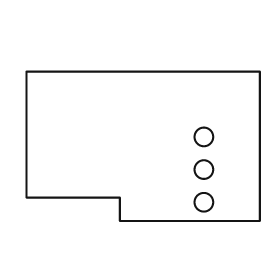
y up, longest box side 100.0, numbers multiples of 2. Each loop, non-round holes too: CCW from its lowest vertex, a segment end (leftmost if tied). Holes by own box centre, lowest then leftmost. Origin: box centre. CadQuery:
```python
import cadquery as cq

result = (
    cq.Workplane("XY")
    .moveTo(-10.0, -32.0)
    .lineTo(50.0, -32.0)
    .lineTo(50.0, 32.0)
    .lineTo(-50.0, 32.0)
    .lineTo(-50.0, -22.0)
    .lineTo(-10.0, -22.0)
    .close()
    .moveTo(26.0, -24.0)
    .circle(4.0)
    .moveTo(26.0, -10.0)
    .circle(4.0)
    .moveTo(26.0, 4.0)
    .circle(4.0)
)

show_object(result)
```